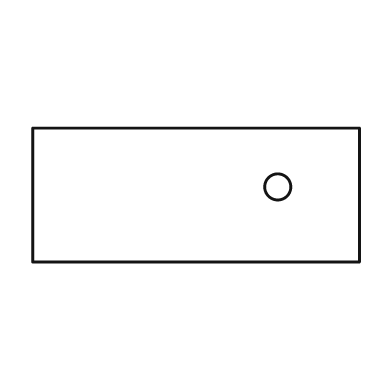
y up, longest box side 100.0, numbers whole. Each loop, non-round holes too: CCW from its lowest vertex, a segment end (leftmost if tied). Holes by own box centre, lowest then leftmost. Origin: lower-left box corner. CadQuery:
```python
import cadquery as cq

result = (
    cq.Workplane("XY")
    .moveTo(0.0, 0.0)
    .lineTo(100.0, 0.0)
    .lineTo(100.0, 41.0)
    .lineTo(0.0, 41.0)
    .close()
    .moveTo(75.0, 23.0)
    .circle(4.0)
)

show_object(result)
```